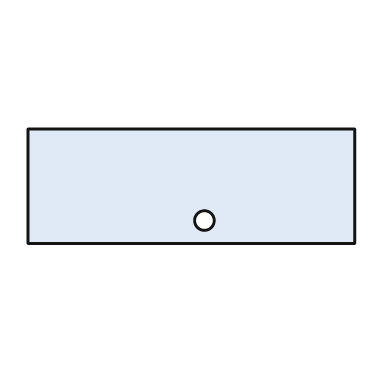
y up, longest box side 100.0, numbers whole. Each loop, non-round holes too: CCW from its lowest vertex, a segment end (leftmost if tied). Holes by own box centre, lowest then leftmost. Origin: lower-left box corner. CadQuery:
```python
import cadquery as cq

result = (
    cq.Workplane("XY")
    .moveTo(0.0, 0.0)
    .lineTo(100.0, 0.0)
    .lineTo(100.0, 35.0)
    .lineTo(0.0, 35.0)
    .close()
    .moveTo(54.0, 7.0)
    .circle(3.0)
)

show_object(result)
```